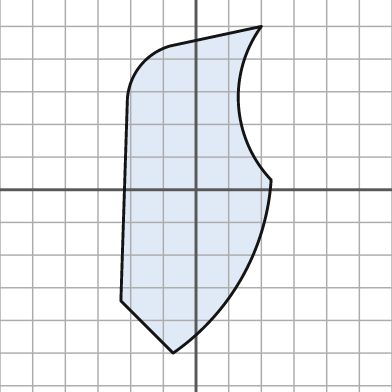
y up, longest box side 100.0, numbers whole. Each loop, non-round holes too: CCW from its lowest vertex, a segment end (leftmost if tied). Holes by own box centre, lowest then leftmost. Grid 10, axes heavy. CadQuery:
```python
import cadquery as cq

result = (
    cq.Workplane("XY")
    .moveTo(-7.0, -50.0)
    .threePointArc((14.0, -27.0), (23.0, 3.0))
    .threePointArc((13.0, 26.0), (20.0, 50.0))
    .lineTo(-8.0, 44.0)
    .threePointArc((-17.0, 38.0), (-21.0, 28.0))
    .lineTo(-23.0, -34.0)
    .close()
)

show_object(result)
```